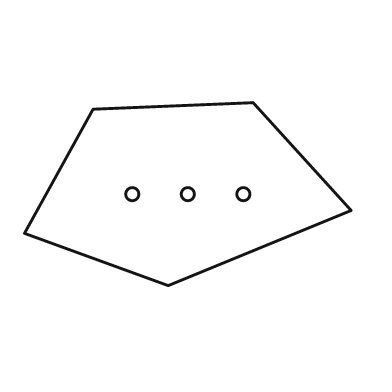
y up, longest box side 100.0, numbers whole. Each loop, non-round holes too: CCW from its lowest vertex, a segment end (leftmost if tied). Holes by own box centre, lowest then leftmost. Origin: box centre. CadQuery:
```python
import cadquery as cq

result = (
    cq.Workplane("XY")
    .moveTo(-6.0, -28.0)
    .lineTo(50.0, -5.0)
    .lineTo(20.0, 28.0)
    .lineTo(-29.0, 26.0)
    .lineTo(-50.0, -12.0)
    .close()
    .moveTo(-17.0, 0.0)
    .circle(2.0)
    .moveTo(0.0, 0.0)
    .circle(2.0)
    .moveTo(17.0, 0.0)
    .circle(2.0)
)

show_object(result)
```